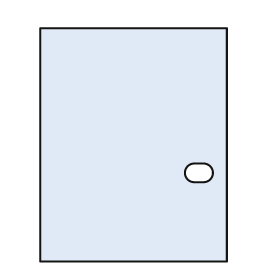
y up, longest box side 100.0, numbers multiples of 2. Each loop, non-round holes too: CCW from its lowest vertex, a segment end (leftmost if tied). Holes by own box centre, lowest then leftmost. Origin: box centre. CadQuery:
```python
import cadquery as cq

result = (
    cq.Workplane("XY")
    .moveTo(-40.0, -50.0)
    .lineTo(40.0, -50.0)
    .lineTo(40.0, 50.0)
    .lineTo(-40.0, 50.0)
    .close()
    .moveTo(26.0, -16.0)
    .lineTo(30.0, -16.0)
    .threePointArc((34.0, -12.0), (30.0, -8.0))
    .lineTo(26.0, -8.0)
    .threePointArc((22.0, -12.0), (26.0, -16.0))
    .close()
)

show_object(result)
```